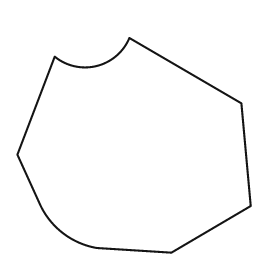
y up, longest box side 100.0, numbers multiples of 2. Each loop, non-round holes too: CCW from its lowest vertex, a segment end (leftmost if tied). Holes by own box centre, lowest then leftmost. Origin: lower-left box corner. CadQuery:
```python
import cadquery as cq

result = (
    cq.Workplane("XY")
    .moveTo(66.0, 0.0)
    .lineTo(100.0, 20.0)
    .lineTo(96.0, 64.0)
    .lineTo(48.0, 92.0)
    .threePointArc((34.0, 80.0), (16.0, 84.0))
    .lineTo(0.0, 42.0)
    .lineTo(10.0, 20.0)
    .threePointArc((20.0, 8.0), (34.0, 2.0))
    .close()
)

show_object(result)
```